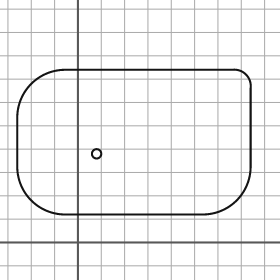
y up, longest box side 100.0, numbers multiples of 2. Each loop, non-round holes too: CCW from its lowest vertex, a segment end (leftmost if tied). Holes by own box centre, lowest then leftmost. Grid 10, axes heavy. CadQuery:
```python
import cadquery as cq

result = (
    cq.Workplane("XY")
    .moveTo(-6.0, 12.0)
    .lineTo(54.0, 12.0)
    .threePointArc((68.0, 18.0), (74.0, 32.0))
    .lineTo(74.0, 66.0)
    .threePointArc((72.0, 72.0), (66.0, 74.0))
    .lineTo(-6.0, 74.0)
    .threePointArc((-20.0, 68.0), (-26.0, 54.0))
    .lineTo(-26.0, 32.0)
    .threePointArc((-20.0, 18.0), (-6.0, 12.0))
    .close()
    .moveTo(8.0, 38.0)
    .circle(2.0)
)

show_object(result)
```